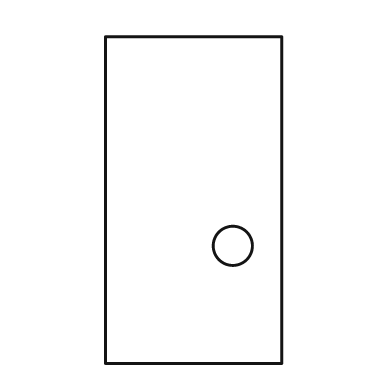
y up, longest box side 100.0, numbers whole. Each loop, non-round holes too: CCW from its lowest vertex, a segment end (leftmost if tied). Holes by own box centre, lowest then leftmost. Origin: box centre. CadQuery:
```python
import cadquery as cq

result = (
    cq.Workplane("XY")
    .moveTo(-27.0, -50.0)
    .lineTo(27.0, -50.0)
    .lineTo(27.0, 50.0)
    .lineTo(-27.0, 50.0)
    .close()
    .moveTo(12.0, -14.0)
    .circle(6.0)
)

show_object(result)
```